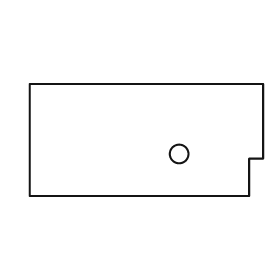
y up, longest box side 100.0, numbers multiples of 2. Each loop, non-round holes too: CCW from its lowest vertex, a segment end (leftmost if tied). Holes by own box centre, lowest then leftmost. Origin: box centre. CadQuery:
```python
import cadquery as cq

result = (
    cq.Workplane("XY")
    .moveTo(-50.0, -24.0)
    .lineTo(44.0, -24.0)
    .lineTo(44.0, -8.0)
    .lineTo(50.0, -8.0)
    .lineTo(50.0, 24.0)
    .lineTo(-50.0, 24.0)
    .close()
    .moveTo(14.0, -6.0)
    .circle(4.0)
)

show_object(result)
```